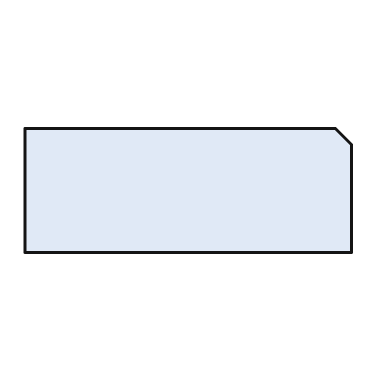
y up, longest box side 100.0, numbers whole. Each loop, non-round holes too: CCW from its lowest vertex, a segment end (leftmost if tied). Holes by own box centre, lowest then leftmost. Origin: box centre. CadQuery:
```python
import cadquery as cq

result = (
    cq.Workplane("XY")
    .moveTo(-50.0, -19.0)
    .lineTo(50.0, -19.0)
    .lineTo(50.0, 14.0)
    .lineTo(45.0, 19.0)
    .lineTo(-50.0, 19.0)
    .close()
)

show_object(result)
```